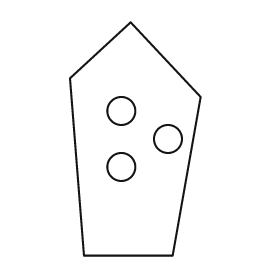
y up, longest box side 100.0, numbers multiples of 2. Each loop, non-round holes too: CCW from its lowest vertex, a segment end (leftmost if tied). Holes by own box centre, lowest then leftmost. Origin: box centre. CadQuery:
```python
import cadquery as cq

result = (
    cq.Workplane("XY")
    .moveTo(-22.0, -50.0)
    .lineTo(16.0, -50.0)
    .lineTo(28.0, 18.0)
    .lineTo(-2.0, 50.0)
    .lineTo(-28.0, 26.0)
    .close()
    .moveTo(-6.0, -12.0)
    .circle(6.0)
    .moveTo(14.0, 0.0)
    .circle(6.0)
    .moveTo(-6.0, 12.0)
    .circle(6.0)
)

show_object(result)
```